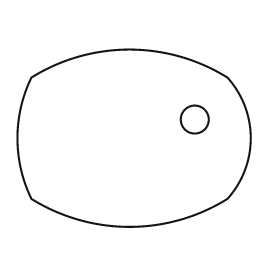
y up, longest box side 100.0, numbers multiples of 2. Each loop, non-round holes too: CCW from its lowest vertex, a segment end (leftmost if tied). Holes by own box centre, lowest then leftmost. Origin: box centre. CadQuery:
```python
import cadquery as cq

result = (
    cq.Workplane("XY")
    .moveTo(-44.0, -26.0)
    .threePointArc((-2.0, -38.0), (40.0, -26.0))
    .threePointArc((50.0, 0.0), (40.0, 26.0))
    .threePointArc((-2.0, 38.0), (-44.0, 26.0))
    .threePointArc((-50.0, 0.0), (-44.0, -26.0))
    .close()
    .moveTo(26.0, 8.0)
    .circle(6.0)
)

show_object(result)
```